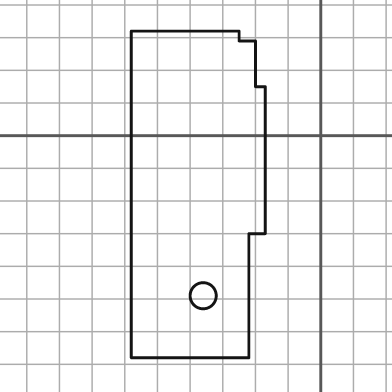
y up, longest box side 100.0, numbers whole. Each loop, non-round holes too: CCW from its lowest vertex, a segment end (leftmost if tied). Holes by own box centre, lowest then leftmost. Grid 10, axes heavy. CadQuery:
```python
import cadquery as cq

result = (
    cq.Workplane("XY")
    .moveTo(-58.0, -68.0)
    .lineTo(-22.0, -68.0)
    .lineTo(-22.0, -30.0)
    .lineTo(-17.0, -30.0)
    .lineTo(-17.0, 15.0)
    .lineTo(-20.0, 15.0)
    .lineTo(-20.0, 29.0)
    .lineTo(-25.0, 29.0)
    .lineTo(-25.0, 32.0)
    .lineTo(-58.0, 32.0)
    .close()
    .moveTo(-36.0, -49.0)
    .circle(4.0)
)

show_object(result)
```